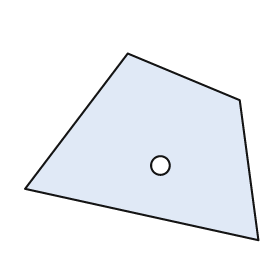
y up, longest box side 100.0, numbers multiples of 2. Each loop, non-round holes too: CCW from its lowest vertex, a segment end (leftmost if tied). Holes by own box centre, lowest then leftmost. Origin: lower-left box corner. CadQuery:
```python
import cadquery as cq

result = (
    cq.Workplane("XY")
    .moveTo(100.0, 0.0)
    .lineTo(92.0, 60.0)
    .lineTo(44.0, 80.0)
    .lineTo(0.0, 22.0)
    .close()
    .moveTo(58.0, 32.0)
    .circle(4.0)
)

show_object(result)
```